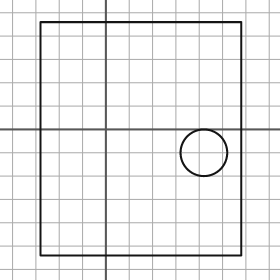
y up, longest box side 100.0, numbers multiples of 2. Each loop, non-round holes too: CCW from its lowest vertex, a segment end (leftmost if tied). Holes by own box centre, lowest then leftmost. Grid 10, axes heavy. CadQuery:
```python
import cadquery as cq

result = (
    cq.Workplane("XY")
    .moveTo(-28.0, -54.0)
    .lineTo(58.0, -54.0)
    .lineTo(58.0, 46.0)
    .lineTo(-28.0, 46.0)
    .close()
    .moveTo(42.0, -10.0)
    .circle(10.0)
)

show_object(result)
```